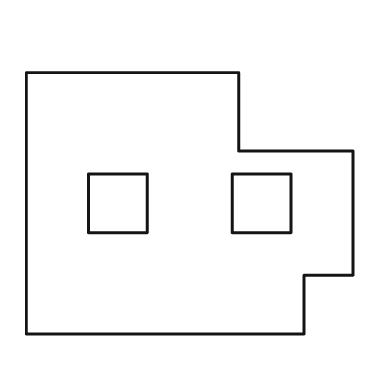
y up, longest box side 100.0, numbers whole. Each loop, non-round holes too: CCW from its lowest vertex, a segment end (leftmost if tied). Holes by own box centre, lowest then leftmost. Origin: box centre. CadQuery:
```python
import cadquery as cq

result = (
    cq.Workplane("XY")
    .moveTo(-50.0, -40.0)
    .lineTo(35.0, -40.0)
    .lineTo(35.0, -22.0)
    .lineTo(50.0, -22.0)
    .lineTo(50.0, 16.0)
    .lineTo(15.0, 16.0)
    .lineTo(15.0, 40.0)
    .lineTo(-50.0, 40.0)
    .close()
    .moveTo(-31.0, -9.0)
    .lineTo(-13.0, -9.0)
    .lineTo(-13.0, 9.0)
    .lineTo(-31.0, 9.0)
    .close()
    .moveTo(13.0, -9.0)
    .lineTo(31.0, -9.0)
    .lineTo(31.0, 9.0)
    .lineTo(13.0, 9.0)
    .close()
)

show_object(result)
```